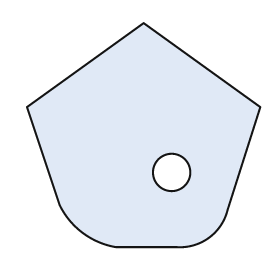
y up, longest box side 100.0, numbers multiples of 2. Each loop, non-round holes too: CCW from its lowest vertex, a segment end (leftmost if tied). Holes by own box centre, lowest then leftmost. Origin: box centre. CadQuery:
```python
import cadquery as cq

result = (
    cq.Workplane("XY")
    .moveTo(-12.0, -48.0)
    .lineTo(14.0, -48.0)
    .threePointArc((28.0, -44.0), (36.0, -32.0))
    .lineTo(50.0, 12.0)
    .lineTo(0.0, 48.0)
    .lineTo(-50.0, 12.0)
    .lineTo(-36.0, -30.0)
    .threePointArc((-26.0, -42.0), (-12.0, -48.0))
    .close()
    .moveTo(12.0, -16.0)
    .circle(8.0)
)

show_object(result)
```